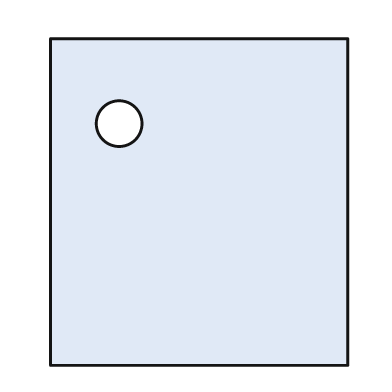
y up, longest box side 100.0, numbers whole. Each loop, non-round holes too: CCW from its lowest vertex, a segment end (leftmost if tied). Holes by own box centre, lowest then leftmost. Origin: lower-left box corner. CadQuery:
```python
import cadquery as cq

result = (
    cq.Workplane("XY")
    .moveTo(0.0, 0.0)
    .lineTo(91.0, 0.0)
    .lineTo(91.0, 100.0)
    .lineTo(0.0, 100.0)
    .close()
    .moveTo(21.0, 74.0)
    .circle(7.0)
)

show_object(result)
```